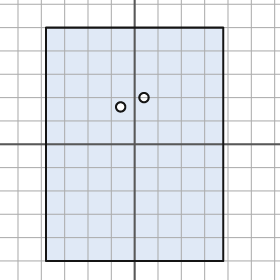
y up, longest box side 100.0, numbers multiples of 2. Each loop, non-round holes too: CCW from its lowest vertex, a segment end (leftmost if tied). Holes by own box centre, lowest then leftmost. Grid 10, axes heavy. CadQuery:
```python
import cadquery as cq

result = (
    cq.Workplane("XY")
    .moveTo(-38.0, -50.0)
    .lineTo(38.0, -50.0)
    .lineTo(38.0, 50.0)
    .lineTo(-38.0, 50.0)
    .close()
    .moveTo(-6.0, 16.0)
    .circle(2.0)
    .moveTo(4.0, 20.0)
    .circle(2.0)
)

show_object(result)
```